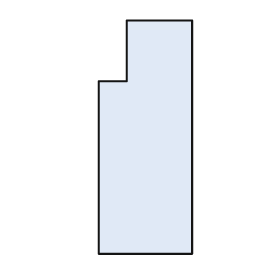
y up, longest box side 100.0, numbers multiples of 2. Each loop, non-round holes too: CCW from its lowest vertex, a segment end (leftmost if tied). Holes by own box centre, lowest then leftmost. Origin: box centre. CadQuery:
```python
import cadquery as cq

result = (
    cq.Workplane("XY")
    .moveTo(-20.0, -50.0)
    .lineTo(20.0, -50.0)
    .lineTo(20.0, 50.0)
    .lineTo(-8.0, 50.0)
    .lineTo(-8.0, 24.0)
    .lineTo(-20.0, 24.0)
    .close()
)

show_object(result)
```